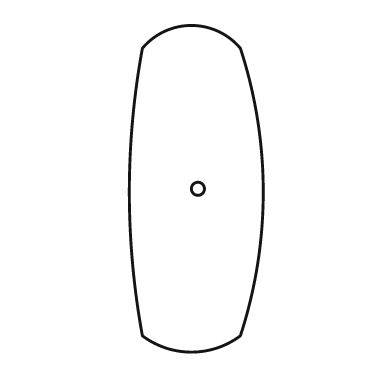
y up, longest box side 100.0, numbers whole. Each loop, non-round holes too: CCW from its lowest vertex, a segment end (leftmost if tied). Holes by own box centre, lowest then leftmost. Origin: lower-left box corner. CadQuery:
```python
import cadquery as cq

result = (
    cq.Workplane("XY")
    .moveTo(4.0, 5.0)
    .threePointArc((19.0, 0.0), (34.0, 5.0))
    .threePointArc((41.0, 49.0), (34.0, 93.0))
    .threePointArc((19.0, 100.0), (4.0, 93.0))
    .threePointArc((0.0, 49.0), (4.0, 5.0))
    .close()
    .moveTo(21.0, 50.0)
    .circle(2.0)
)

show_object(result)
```